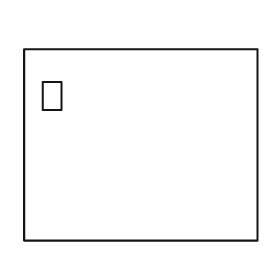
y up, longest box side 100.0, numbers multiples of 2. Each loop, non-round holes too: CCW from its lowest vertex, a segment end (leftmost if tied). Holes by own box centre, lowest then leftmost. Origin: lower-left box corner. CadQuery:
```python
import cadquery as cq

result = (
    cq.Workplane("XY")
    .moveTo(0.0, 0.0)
    .lineTo(100.0, 0.0)
    .lineTo(100.0, 82.0)
    .lineTo(0.0, 82.0)
    .close()
    .moveTo(8.0, 56.0)
    .lineTo(16.0, 56.0)
    .lineTo(16.0, 68.0)
    .lineTo(8.0, 68.0)
    .close()
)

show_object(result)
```